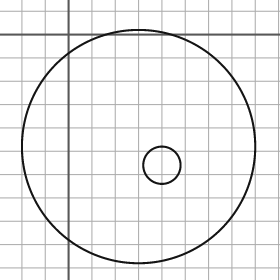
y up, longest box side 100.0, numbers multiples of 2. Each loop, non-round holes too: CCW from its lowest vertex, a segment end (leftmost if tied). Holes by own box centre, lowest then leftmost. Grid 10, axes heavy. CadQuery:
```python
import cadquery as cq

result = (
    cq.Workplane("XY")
    .moveTo(30.0, -48.0)
    .circle(50.0)
    .moveTo(40.0, -56.0)
    .circle(8.0)
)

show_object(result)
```